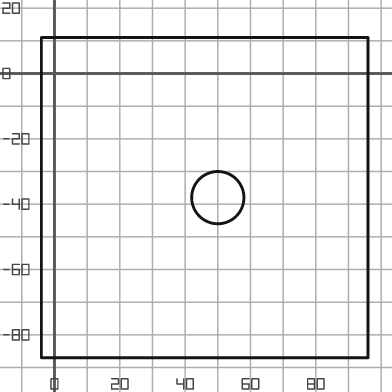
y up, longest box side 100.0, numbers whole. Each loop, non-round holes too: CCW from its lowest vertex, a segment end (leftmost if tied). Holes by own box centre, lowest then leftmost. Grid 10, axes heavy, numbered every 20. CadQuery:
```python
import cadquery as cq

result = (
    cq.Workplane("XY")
    .moveTo(-4.0, -87.0)
    .lineTo(96.0, -87.0)
    .lineTo(96.0, 11.0)
    .lineTo(-4.0, 11.0)
    .close()
    .moveTo(50.0, -38.0)
    .circle(8.0)
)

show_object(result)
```